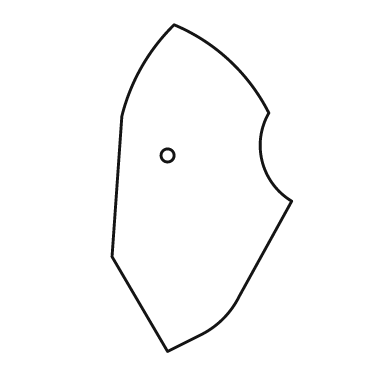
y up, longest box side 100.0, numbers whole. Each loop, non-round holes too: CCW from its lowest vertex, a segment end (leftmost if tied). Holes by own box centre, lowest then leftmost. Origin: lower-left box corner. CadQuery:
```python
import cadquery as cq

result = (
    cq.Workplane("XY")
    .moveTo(17.0, 0.0)
    .lineTo(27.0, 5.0)
    .threePointArc((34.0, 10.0), (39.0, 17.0))
    .lineTo(55.0, 46.0)
    .threePointArc((46.0, 58.0), (48.0, 73.0))
    .threePointArc((36.0, 89.0), (19.0, 100.0))
    .threePointArc((9.0, 87.0), (3.0, 72.0))
    .lineTo(0.0, 29.0)
    .close()
    .moveTo(17.0, 60.0)
    .circle(2.0)
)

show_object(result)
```